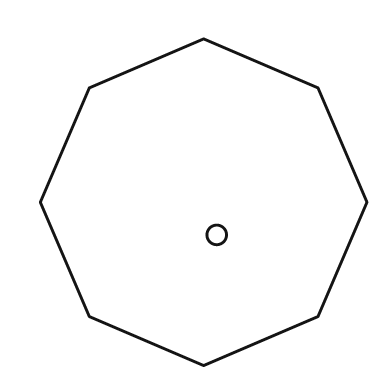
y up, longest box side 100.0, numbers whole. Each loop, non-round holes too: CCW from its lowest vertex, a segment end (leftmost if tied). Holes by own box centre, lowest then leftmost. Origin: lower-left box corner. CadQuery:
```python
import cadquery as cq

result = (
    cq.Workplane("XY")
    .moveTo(50.0, 0.0)
    .lineTo(85.0, 15.0)
    .lineTo(100.0, 50.0)
    .lineTo(85.0, 85.0)
    .lineTo(50.0, 100.0)
    .lineTo(15.0, 85.0)
    .lineTo(0.0, 50.0)
    .lineTo(15.0, 15.0)
    .close()
    .moveTo(54.0, 40.0)
    .circle(3.0)
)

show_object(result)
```